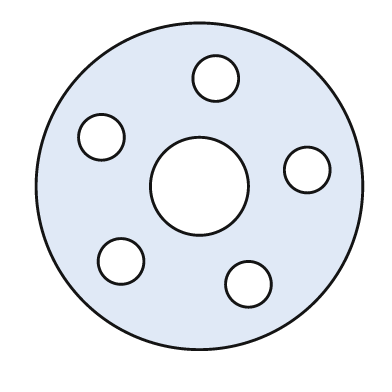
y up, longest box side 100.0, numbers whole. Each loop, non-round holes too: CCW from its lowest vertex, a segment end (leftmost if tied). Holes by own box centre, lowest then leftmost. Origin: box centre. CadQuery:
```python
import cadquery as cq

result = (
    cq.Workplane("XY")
    .moveTo(0.0, 0.0)
    .circle(50.0)
    .moveTo(15.0, -30.0)
    .circle(7.0)
    .moveTo(-24.0, -23.0)
    .circle(7.0)
    .moveTo(0.0, 0.0)
    .circle(15.0)
    .moveTo(33.0, 5.0)
    .circle(7.0)
    .moveTo(-30.0, 15.0)
    .circle(7.0)
    .moveTo(5.0, 33.0)
    .circle(7.0)
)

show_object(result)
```